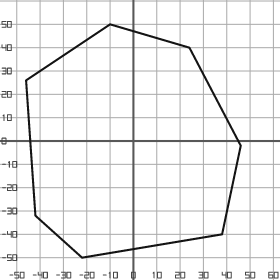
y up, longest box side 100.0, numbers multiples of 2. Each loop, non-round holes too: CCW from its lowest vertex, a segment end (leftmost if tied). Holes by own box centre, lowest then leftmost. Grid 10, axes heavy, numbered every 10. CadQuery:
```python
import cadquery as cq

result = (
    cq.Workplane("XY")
    .moveTo(-22.0, -50.0)
    .lineTo(38.0, -40.0)
    .lineTo(46.0, -2.0)
    .lineTo(24.0, 40.0)
    .lineTo(-10.0, 50.0)
    .lineTo(-46.0, 26.0)
    .lineTo(-42.0, -32.0)
    .close()
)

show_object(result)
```